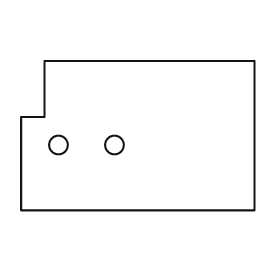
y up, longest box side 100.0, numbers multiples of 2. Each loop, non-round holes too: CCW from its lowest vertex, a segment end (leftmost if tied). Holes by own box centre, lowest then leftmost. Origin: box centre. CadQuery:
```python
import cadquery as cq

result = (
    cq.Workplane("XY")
    .moveTo(-50.0, -32.0)
    .lineTo(50.0, -32.0)
    .lineTo(50.0, 32.0)
    .lineTo(-40.0, 32.0)
    .lineTo(-40.0, 8.0)
    .lineTo(-50.0, 8.0)
    .close()
    .moveTo(-34.0, -4.0)
    .circle(4.0)
    .moveTo(-10.0, -4.0)
    .circle(4.0)
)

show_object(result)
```